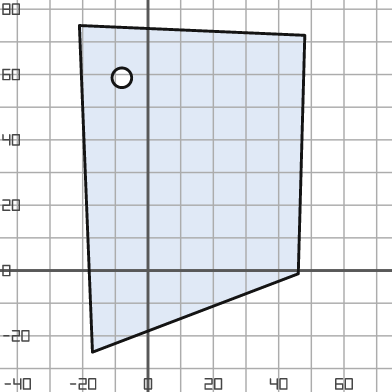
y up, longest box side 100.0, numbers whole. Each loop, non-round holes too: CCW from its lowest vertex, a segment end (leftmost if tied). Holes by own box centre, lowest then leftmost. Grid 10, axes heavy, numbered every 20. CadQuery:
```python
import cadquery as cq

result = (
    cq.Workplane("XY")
    .moveTo(-17.0, -25.0)
    .lineTo(46.0, -1.0)
    .lineTo(48.0, 72.0)
    .lineTo(-21.0, 75.0)
    .close()
    .moveTo(-8.0, 59.0)
    .circle(3.0)
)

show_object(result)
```